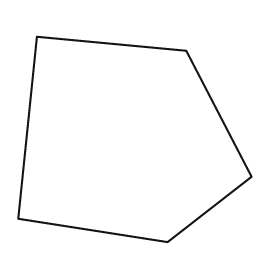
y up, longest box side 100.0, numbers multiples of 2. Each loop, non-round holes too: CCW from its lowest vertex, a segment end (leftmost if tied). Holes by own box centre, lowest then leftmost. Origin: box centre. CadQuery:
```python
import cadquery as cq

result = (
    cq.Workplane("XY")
    .moveTo(14.0, -44.0)
    .lineTo(50.0, -16.0)
    .lineTo(22.0, 38.0)
    .lineTo(-42.0, 44.0)
    .lineTo(-50.0, -34.0)
    .close()
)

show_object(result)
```